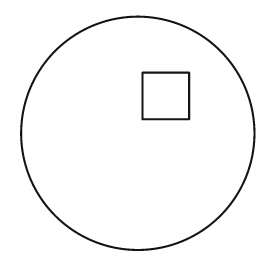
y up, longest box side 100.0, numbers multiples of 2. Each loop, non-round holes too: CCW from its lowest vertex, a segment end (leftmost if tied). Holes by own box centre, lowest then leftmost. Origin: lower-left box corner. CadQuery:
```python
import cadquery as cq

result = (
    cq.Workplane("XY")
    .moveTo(50.0, 50.0)
    .circle(50.0)
    .moveTo(52.0, 56.0)
    .lineTo(72.0, 56.0)
    .lineTo(72.0, 76.0)
    .lineTo(52.0, 76.0)
    .close()
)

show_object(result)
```